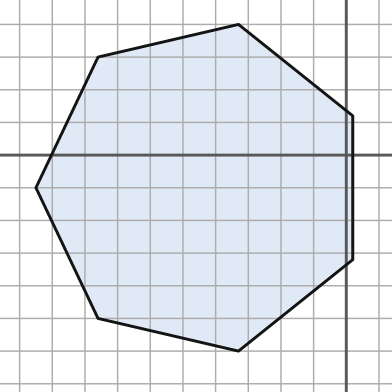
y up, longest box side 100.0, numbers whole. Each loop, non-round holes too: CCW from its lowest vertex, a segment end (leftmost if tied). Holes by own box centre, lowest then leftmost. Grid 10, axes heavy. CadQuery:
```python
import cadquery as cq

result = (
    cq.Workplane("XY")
    .moveTo(-33.0, -60.0)
    .lineTo(2.0, -32.0)
    .lineTo(2.0, 12.0)
    .lineTo(-33.0, 40.0)
    .lineTo(-76.0, 30.0)
    .lineTo(-95.0, -10.0)
    .lineTo(-76.0, -50.0)
    .close()
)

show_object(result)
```